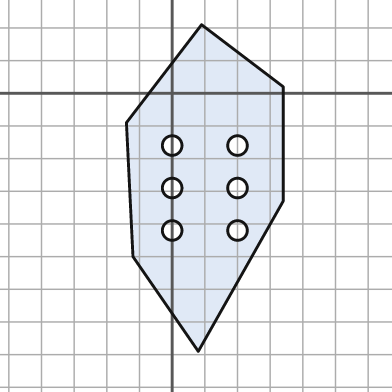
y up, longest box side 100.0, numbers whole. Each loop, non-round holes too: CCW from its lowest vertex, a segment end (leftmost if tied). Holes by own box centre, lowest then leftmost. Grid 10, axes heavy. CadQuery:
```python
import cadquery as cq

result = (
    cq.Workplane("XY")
    .moveTo(8.0, -79.0)
    .lineTo(34.0, -33.0)
    .lineTo(34.0, 2.0)
    .lineTo(9.0, 21.0)
    .lineTo(-14.0, -9.0)
    .lineTo(-12.0, -50.0)
    .close()
    .moveTo(0.0, -42.0)
    .circle(3.0)
    .moveTo(20.0, -42.0)
    .circle(3.0)
    .moveTo(0.0, -29.0)
    .circle(3.0)
    .moveTo(20.0, -29.0)
    .circle(3.0)
    .moveTo(0.0, -16.0)
    .circle(3.0)
    .moveTo(20.0, -16.0)
    .circle(3.0)
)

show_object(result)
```